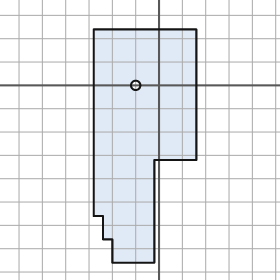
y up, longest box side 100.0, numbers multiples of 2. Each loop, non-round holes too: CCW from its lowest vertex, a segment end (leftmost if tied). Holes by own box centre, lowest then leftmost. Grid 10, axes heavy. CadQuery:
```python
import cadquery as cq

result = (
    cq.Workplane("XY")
    .moveTo(-20.0, -76.0)
    .lineTo(-2.0, -76.0)
    .lineTo(-2.0, -32.0)
    .lineTo(16.0, -32.0)
    .lineTo(16.0, 24.0)
    .lineTo(-28.0, 24.0)
    .lineTo(-28.0, -56.0)
    .lineTo(-24.0, -56.0)
    .lineTo(-24.0, -66.0)
    .lineTo(-20.0, -66.0)
    .close()
    .moveTo(-10.0, 0.0)
    .circle(2.0)
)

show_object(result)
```